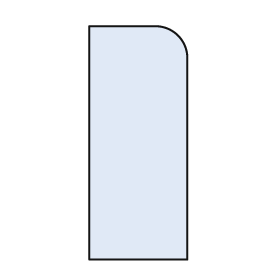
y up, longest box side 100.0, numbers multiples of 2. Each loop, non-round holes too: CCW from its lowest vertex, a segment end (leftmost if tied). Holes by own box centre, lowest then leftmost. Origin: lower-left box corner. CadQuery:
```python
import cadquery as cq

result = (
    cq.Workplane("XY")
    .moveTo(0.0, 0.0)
    .lineTo(42.0, 0.0)
    .lineTo(42.0, 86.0)
    .threePointArc((38.0, 96.0), (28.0, 100.0))
    .lineTo(0.0, 100.0)
    .close()
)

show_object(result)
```